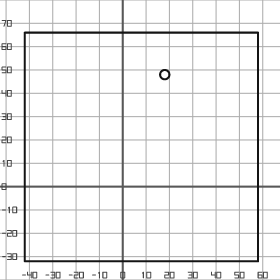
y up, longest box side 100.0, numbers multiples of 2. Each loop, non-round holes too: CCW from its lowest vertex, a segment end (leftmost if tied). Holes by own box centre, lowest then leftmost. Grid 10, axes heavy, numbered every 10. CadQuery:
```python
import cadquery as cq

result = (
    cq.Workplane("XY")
    .moveTo(-42.0, -32.0)
    .lineTo(58.0, -32.0)
    .lineTo(58.0, 66.0)
    .lineTo(-42.0, 66.0)
    .close()
    .moveTo(18.0, 48.0)
    .circle(2.0)
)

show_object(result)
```